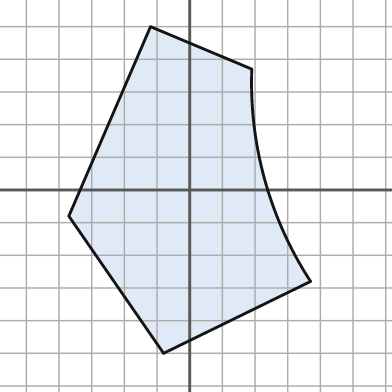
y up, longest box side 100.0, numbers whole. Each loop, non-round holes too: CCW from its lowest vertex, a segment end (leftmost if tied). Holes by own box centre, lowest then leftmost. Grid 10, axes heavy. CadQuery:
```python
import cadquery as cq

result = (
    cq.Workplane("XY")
    .moveTo(-8.0, -50.0)
    .lineTo(37.0, -28.0)
    .threePointArc((23.0, 3.0), (19.0, 37.0))
    .lineTo(-12.0, 50.0)
    .lineTo(-37.0, -8.0)
    .close()
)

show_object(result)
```